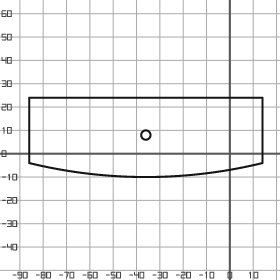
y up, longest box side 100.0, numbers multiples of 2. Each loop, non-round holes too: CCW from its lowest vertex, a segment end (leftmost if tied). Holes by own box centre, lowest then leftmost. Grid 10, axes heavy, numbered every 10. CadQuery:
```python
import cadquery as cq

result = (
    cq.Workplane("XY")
    .moveTo(-86.0, -4.0)
    .threePointArc((-36.0, -10.0), (14.0, -4.0))
    .lineTo(14.0, 24.0)
    .lineTo(-86.0, 24.0)
    .close()
    .moveTo(-36.0, 8.0)
    .circle(2.0)
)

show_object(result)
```